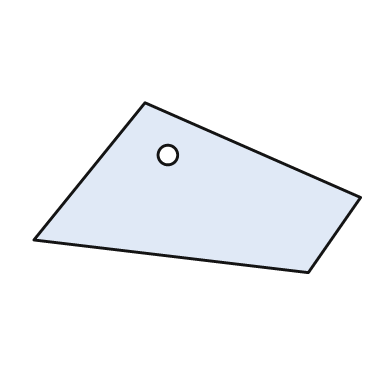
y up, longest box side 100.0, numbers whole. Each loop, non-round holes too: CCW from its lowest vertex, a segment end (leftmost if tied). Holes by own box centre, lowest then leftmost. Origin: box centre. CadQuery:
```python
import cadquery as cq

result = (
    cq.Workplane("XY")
    .moveTo(34.0, -26.0)
    .lineTo(50.0, -3.0)
    .lineTo(-16.0, 26.0)
    .lineTo(-50.0, -16.0)
    .close()
    .moveTo(-9.0, 10.0)
    .circle(3.0)
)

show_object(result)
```